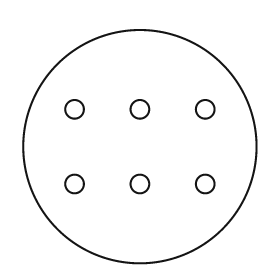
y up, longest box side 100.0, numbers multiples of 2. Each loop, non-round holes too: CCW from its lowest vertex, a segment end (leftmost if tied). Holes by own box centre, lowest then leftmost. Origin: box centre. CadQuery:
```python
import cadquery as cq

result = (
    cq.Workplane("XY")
    .moveTo(0.0, 0.0)
    .circle(50.0)
    .moveTo(-28.0, -16.0)
    .circle(4.0)
    .moveTo(0.0, -16.0)
    .circle(4.0)
    .moveTo(28.0, -16.0)
    .circle(4.0)
    .moveTo(-28.0, 16.0)
    .circle(4.0)
    .moveTo(0.0, 16.0)
    .circle(4.0)
    .moveTo(28.0, 16.0)
    .circle(4.0)
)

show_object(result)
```